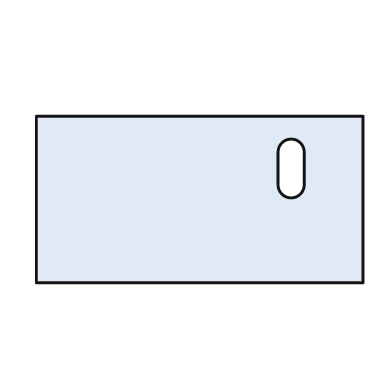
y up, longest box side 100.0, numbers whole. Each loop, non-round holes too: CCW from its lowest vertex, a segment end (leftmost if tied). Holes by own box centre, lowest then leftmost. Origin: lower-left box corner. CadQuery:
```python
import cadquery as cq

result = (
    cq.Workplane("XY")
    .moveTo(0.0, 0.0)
    .lineTo(100.0, 0.0)
    .lineTo(100.0, 51.0)
    .lineTo(0.0, 51.0)
    .close()
    .moveTo(74.0, 30.0)
    .threePointArc((78.0, 26.0), (82.0, 30.0))
    .lineTo(82.0, 40.0)
    .threePointArc((78.0, 44.0), (74.0, 40.0))
    .close()
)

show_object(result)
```